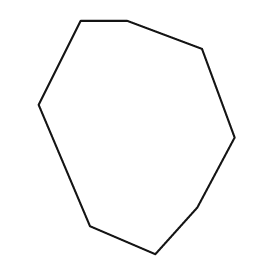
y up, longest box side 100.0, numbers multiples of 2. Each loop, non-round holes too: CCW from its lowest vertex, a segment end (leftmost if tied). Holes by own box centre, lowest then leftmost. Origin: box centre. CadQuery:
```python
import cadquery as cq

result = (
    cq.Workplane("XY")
    .moveTo(8.0, -50.0)
    .lineTo(26.0, -30.0)
    .lineTo(42.0, 0.0)
    .lineTo(28.0, 38.0)
    .lineTo(-4.0, 50.0)
    .lineTo(-24.0, 50.0)
    .lineTo(-42.0, 14.0)
    .lineTo(-20.0, -38.0)
    .close()
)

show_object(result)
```